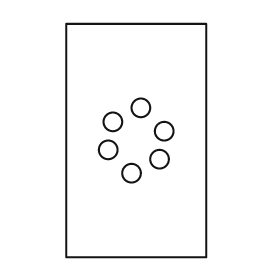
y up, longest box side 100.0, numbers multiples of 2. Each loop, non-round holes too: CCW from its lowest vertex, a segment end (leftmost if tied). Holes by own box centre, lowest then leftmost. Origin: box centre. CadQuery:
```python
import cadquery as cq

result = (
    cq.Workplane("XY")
    .moveTo(-30.0, -50.0)
    .lineTo(30.0, -50.0)
    .lineTo(30.0, 50.0)
    .lineTo(-30.0, 50.0)
    .close()
    .moveTo(-2.0, -14.0)
    .circle(4.0)
    .moveTo(10.0, -8.0)
    .circle(4.0)
    .moveTo(-12.0, -4.0)
    .circle(4.0)
    .moveTo(12.0, 4.0)
    .circle(4.0)
    .moveTo(-10.0, 8.0)
    .circle(4.0)
    .moveTo(2.0, 14.0)
    .circle(4.0)
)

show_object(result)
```